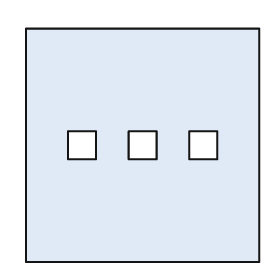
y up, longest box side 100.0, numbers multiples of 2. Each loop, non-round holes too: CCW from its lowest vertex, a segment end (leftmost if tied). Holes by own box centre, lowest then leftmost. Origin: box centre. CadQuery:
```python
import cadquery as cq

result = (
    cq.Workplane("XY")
    .moveTo(-50.0, -50.0)
    .lineTo(50.0, -50.0)
    .lineTo(50.0, 50.0)
    .lineTo(-50.0, 50.0)
    .close()
    .moveTo(-32.0, -6.0)
    .lineTo(-20.0, -6.0)
    .lineTo(-20.0, 6.0)
    .lineTo(-32.0, 6.0)
    .close()
    .moveTo(-6.0, -6.0)
    .lineTo(6.0, -6.0)
    .lineTo(6.0, 6.0)
    .lineTo(-6.0, 6.0)
    .close()
    .moveTo(20.0, -6.0)
    .lineTo(32.0, -6.0)
    .lineTo(32.0, 6.0)
    .lineTo(20.0, 6.0)
    .close()
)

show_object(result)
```